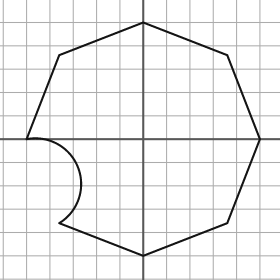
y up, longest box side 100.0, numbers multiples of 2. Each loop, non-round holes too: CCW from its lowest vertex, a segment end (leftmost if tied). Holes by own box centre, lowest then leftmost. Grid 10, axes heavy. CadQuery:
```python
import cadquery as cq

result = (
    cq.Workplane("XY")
    .moveTo(0.0, -50.0)
    .lineTo(36.0, -36.0)
    .lineTo(50.0, 0.0)
    .lineTo(36.0, 36.0)
    .lineTo(0.0, 50.0)
    .lineTo(-36.0, 36.0)
    .lineTo(-50.0, 0.0)
    .threePointArc((-28.0, -12.0), (-36.0, -36.0))
    .close()
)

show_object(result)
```